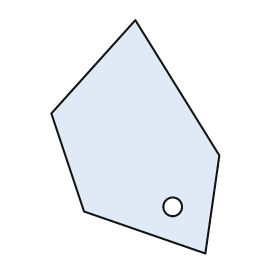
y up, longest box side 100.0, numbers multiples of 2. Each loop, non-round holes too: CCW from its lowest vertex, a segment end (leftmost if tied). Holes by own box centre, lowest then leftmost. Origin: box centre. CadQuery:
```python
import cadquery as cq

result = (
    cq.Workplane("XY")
    .moveTo(30.0, -50.0)
    .lineTo(36.0, -8.0)
    .lineTo(0.0, 50.0)
    .lineTo(-36.0, 10.0)
    .lineTo(-22.0, -32.0)
    .close()
    .moveTo(16.0, -30.0)
    .circle(4.0)
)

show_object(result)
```